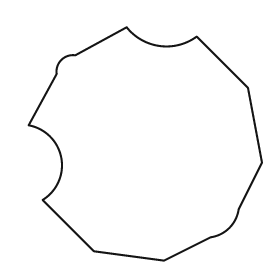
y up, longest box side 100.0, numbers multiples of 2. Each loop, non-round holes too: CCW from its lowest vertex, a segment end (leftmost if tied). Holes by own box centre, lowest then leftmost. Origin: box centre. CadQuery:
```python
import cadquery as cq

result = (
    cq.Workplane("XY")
    .moveTo(8.0, -50.0)
    .lineTo(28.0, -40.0)
    .threePointArc((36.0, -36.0), (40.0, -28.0))
    .lineTo(50.0, -8.0)
    .lineTo(44.0, 24.0)
    .lineTo(22.0, 46.0)
    .threePointArc((6.0, 42.0), (-8.0, 50.0))
    .lineTo(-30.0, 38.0)
    .threePointArc((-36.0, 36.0), (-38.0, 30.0))
    .lineTo(-50.0, 8.0)
    .threePointArc((-36.0, -6.0), (-44.0, -24.0))
    .lineTo(-22.0, -46.0)
    .close()
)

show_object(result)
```